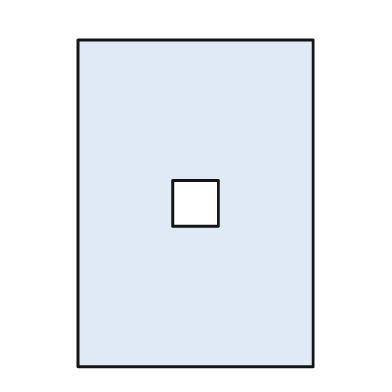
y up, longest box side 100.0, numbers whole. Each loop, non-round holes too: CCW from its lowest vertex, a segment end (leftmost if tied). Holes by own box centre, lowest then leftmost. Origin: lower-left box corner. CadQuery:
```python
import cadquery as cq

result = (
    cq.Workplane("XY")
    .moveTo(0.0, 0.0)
    .lineTo(72.0, 0.0)
    .lineTo(72.0, 100.0)
    .lineTo(0.0, 100.0)
    .close()
    .moveTo(29.0, 43.0)
    .lineTo(43.0, 43.0)
    .lineTo(43.0, 57.0)
    .lineTo(29.0, 57.0)
    .close()
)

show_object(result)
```